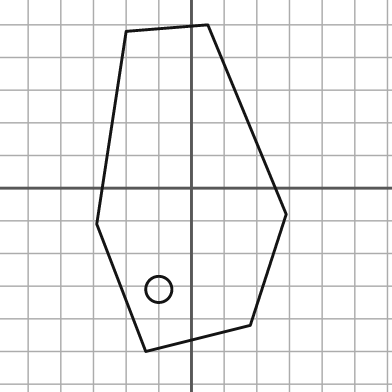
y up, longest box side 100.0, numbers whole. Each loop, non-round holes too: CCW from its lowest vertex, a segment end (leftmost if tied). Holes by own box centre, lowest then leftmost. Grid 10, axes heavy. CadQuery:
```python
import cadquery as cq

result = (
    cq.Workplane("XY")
    .moveTo(-14.0, -50.0)
    .lineTo(18.0, -42.0)
    .lineTo(29.0, -8.0)
    .lineTo(5.0, 50.0)
    .lineTo(-20.0, 48.0)
    .lineTo(-29.0, -11.0)
    .close()
    .moveTo(-10.0, -31.0)
    .circle(4.0)
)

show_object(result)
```